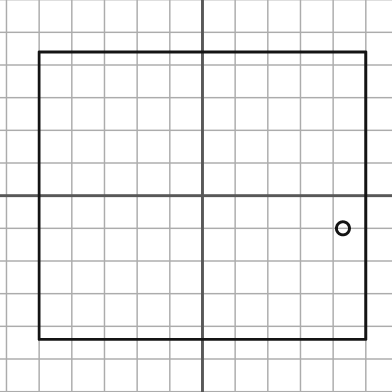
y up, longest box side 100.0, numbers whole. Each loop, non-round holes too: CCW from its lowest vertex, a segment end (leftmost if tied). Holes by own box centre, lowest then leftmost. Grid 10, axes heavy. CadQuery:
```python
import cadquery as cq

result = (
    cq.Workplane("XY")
    .moveTo(-50.0, -44.0)
    .lineTo(50.0, -44.0)
    .lineTo(50.0, 44.0)
    .lineTo(-50.0, 44.0)
    .close()
    .moveTo(43.0, -10.0)
    .circle(2.0)
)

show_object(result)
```